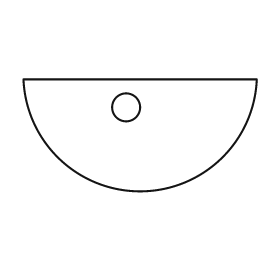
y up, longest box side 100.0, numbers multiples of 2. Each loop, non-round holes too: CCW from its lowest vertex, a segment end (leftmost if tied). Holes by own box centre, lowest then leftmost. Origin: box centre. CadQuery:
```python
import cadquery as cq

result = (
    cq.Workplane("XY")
    .moveTo(-50.0, 24.0)
    .threePointArc((0.0, -24.0), (50.0, 24.0))
    .close()
    .moveTo(-6.0, 12.0)
    .circle(6.0)
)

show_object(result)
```